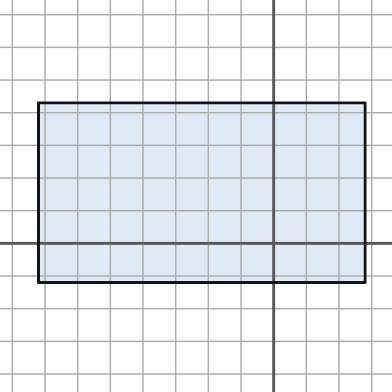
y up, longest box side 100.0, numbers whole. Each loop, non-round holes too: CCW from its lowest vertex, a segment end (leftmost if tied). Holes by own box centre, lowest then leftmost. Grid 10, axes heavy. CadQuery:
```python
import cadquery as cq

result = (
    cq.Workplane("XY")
    .moveTo(-72.0, -12.0)
    .lineTo(28.0, -12.0)
    .lineTo(28.0, 43.0)
    .lineTo(-72.0, 43.0)
    .close()
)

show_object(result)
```